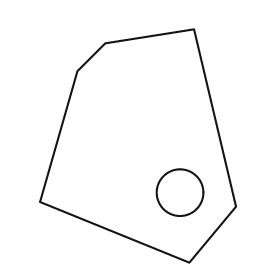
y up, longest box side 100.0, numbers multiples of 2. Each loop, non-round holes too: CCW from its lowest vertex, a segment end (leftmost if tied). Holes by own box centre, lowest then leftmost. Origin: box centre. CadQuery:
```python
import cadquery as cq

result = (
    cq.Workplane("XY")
    .moveTo(22.0, -50.0)
    .lineTo(42.0, -26.0)
    .lineTo(24.0, 50.0)
    .lineTo(-14.0, 44.0)
    .lineTo(-26.0, 32.0)
    .lineTo(-42.0, -24.0)
    .close()
    .moveTo(18.0, -20.0)
    .circle(10.0)
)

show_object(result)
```